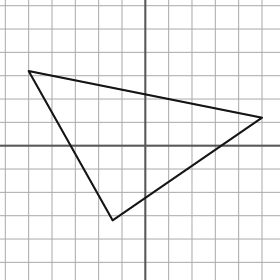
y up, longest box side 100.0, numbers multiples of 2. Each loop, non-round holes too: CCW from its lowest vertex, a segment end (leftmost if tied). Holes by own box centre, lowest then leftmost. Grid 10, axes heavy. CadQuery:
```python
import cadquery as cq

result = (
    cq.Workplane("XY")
    .moveTo(-14.0, -32.0)
    .lineTo(50.0, 12.0)
    .lineTo(-50.0, 32.0)
    .close()
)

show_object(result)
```